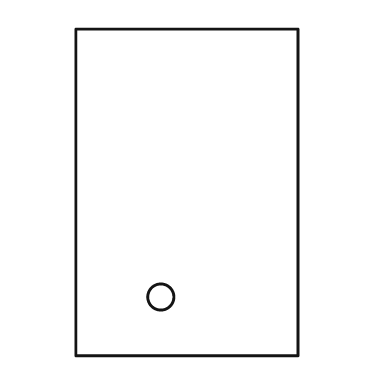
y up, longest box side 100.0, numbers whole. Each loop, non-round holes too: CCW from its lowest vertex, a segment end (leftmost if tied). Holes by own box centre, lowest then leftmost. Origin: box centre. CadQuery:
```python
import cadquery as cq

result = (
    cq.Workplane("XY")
    .moveTo(-34.0, -50.0)
    .lineTo(34.0, -50.0)
    .lineTo(34.0, 50.0)
    .lineTo(-34.0, 50.0)
    .close()
    .moveTo(-8.0, -32.0)
    .circle(4.0)
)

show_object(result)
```